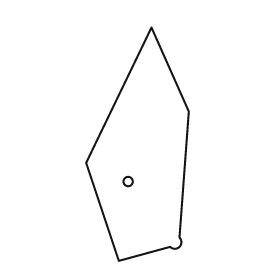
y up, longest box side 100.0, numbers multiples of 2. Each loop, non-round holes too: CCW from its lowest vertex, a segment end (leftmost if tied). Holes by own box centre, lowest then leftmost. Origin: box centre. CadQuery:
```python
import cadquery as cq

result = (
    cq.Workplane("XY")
    .moveTo(-8.0, -50.0)
    .lineTo(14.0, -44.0)
    .threePointArc((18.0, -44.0), (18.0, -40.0))
    .lineTo(22.0, 14.0)
    .lineTo(6.0, 50.0)
    .lineTo(-22.0, -8.0)
    .close()
    .moveTo(-4.0, -16.0)
    .circle(2.0)
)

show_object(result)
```